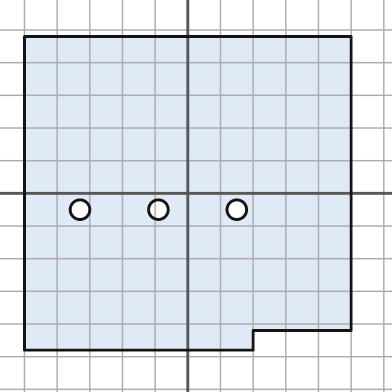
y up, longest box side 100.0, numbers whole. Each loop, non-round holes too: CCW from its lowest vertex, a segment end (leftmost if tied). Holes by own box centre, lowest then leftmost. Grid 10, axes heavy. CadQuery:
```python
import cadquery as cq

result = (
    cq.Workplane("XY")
    .moveTo(-50.0, -48.0)
    .lineTo(20.0, -48.0)
    .lineTo(20.0, -42.0)
    .lineTo(50.0, -42.0)
    .lineTo(50.0, 48.0)
    .lineTo(-50.0, 48.0)
    .close()
    .moveTo(-33.0, -5.0)
    .circle(3.0)
    .moveTo(-9.0, -5.0)
    .circle(3.0)
    .moveTo(15.0, -5.0)
    .circle(3.0)
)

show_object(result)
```